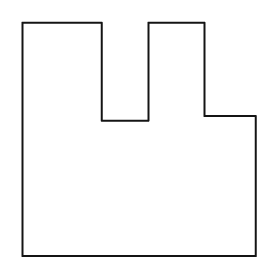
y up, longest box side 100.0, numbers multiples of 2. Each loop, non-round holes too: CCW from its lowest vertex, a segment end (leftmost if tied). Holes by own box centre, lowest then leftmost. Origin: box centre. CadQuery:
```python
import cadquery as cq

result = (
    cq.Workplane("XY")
    .moveTo(-50.0, -50.0)
    .lineTo(50.0, -50.0)
    .lineTo(50.0, 10.0)
    .lineTo(28.0, 10.0)
    .lineTo(28.0, 50.0)
    .lineTo(4.0, 50.0)
    .lineTo(4.0, 8.0)
    .lineTo(-16.0, 8.0)
    .lineTo(-16.0, 50.0)
    .lineTo(-50.0, 50.0)
    .close()
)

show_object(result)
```